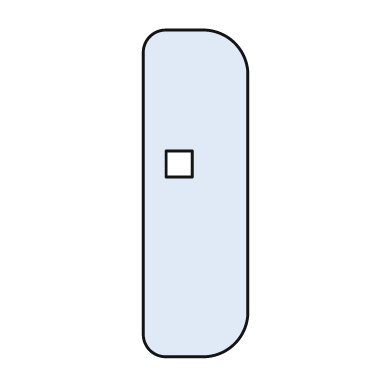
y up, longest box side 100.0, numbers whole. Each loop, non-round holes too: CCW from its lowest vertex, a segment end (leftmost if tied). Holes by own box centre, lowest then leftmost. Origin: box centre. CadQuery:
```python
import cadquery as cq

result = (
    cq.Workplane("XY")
    .moveTo(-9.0, -50.0)
    .lineTo(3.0, -50.0)
    .threePointArc((12.0, -46.0), (16.0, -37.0))
    .lineTo(16.0, 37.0)
    .threePointArc((12.0, 46.0), (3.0, 50.0))
    .lineTo(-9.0, 50.0)
    .threePointArc((-14.0, 48.0), (-16.0, 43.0))
    .lineTo(-16.0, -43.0)
    .threePointArc((-14.0, -48.0), (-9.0, -50.0))
    .close()
    .moveTo(-9.0, 5.0)
    .lineTo(-1.0, 5.0)
    .lineTo(-1.0, 13.0)
    .lineTo(-9.0, 13.0)
    .close()
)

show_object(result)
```